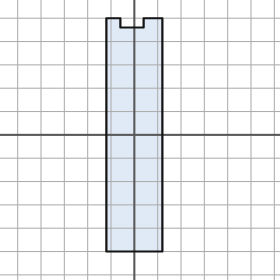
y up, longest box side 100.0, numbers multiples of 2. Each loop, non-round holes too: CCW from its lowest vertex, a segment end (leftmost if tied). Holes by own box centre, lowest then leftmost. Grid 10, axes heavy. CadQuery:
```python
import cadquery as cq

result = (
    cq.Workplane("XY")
    .moveTo(-12.0, -50.0)
    .lineTo(12.0, -50.0)
    .lineTo(12.0, 50.0)
    .lineTo(4.0, 50.0)
    .lineTo(4.0, 46.0)
    .lineTo(-6.0, 46.0)
    .lineTo(-6.0, 50.0)
    .lineTo(-12.0, 50.0)
    .close()
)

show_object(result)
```